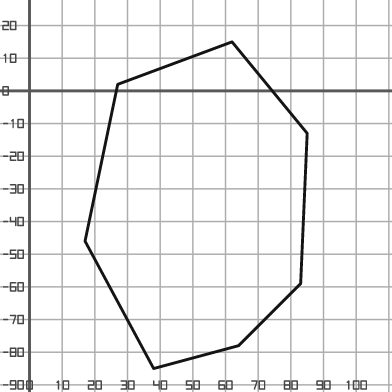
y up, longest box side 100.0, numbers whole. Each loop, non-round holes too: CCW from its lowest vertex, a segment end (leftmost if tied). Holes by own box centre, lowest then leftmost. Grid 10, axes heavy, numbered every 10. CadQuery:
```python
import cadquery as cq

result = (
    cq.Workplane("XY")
    .moveTo(38.0, -85.0)
    .lineTo(64.0, -78.0)
    .lineTo(83.0, -59.0)
    .lineTo(85.0, -13.0)
    .lineTo(62.0, 15.0)
    .lineTo(27.0, 2.0)
    .lineTo(17.0, -46.0)
    .close()
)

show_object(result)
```